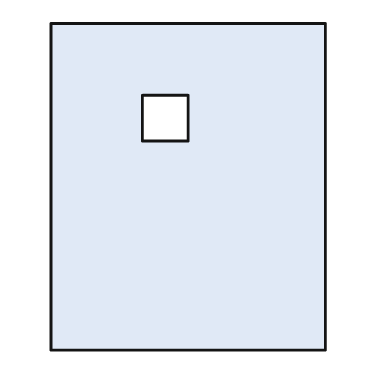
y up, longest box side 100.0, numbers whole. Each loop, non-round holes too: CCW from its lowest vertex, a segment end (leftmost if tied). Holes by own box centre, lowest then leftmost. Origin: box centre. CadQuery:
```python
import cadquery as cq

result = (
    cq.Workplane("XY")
    .moveTo(-42.0, -50.0)
    .lineTo(42.0, -50.0)
    .lineTo(42.0, 50.0)
    .lineTo(-42.0, 50.0)
    .close()
    .moveTo(-14.0, 14.0)
    .lineTo(0.0, 14.0)
    .lineTo(0.0, 28.0)
    .lineTo(-14.0, 28.0)
    .close()
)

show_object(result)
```